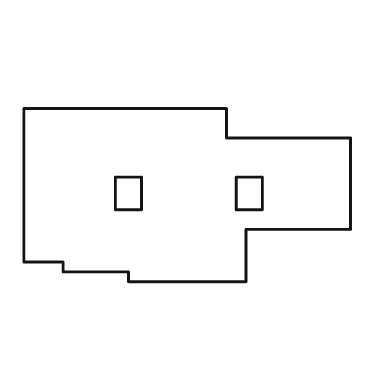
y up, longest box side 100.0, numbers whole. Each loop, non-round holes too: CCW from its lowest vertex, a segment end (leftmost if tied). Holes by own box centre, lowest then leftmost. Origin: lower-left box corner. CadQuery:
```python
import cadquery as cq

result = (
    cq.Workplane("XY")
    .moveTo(32.0, 0.0)
    .lineTo(68.0, 0.0)
    .lineTo(68.0, 16.0)
    .lineTo(100.0, 16.0)
    .lineTo(100.0, 44.0)
    .lineTo(62.0, 44.0)
    .lineTo(62.0, 53.0)
    .lineTo(0.0, 53.0)
    .lineTo(0.0, 6.0)
    .lineTo(12.0, 6.0)
    .lineTo(12.0, 3.0)
    .lineTo(32.0, 3.0)
    .close()
    .moveTo(28.0, 22.0)
    .lineTo(36.0, 22.0)
    .lineTo(36.0, 32.0)
    .lineTo(28.0, 32.0)
    .close()
    .moveTo(65.0, 22.0)
    .lineTo(73.0, 22.0)
    .lineTo(73.0, 32.0)
    .lineTo(65.0, 32.0)
    .close()
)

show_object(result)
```